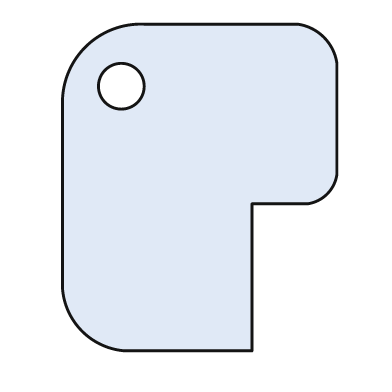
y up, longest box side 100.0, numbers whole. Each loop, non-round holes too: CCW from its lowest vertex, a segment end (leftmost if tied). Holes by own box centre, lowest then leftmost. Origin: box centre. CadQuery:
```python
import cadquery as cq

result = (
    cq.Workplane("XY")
    .moveTo(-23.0, -50.0)
    .lineTo(16.0, -50.0)
    .lineTo(16.0, -5.0)
    .lineTo(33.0, -5.0)
    .threePointArc((39.0, -2.0), (42.0, 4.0))
    .lineTo(42.0, 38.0)
    .threePointArc((38.0, 46.0), (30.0, 50.0))
    .lineTo(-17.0, 50.0)
    .threePointArc((-35.0, 43.0), (-42.0, 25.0))
    .lineTo(-42.0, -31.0)
    .threePointArc((-36.0, -44.0), (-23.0, -50.0))
    .close()
    .moveTo(-24.0, 31.0)
    .circle(7.0)
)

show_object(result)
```